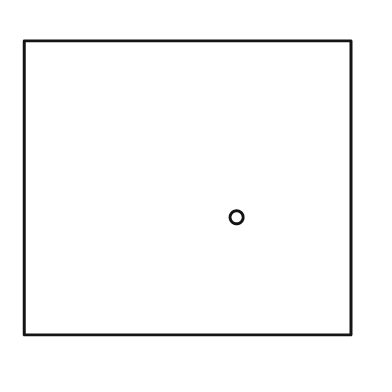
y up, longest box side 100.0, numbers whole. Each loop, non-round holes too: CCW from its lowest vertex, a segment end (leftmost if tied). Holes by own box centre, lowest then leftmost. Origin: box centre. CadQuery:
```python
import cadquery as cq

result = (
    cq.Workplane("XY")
    .moveTo(-50.0, -45.0)
    .lineTo(50.0, -45.0)
    .lineTo(50.0, 45.0)
    .lineTo(-50.0, 45.0)
    .close()
    .moveTo(15.0, -9.0)
    .circle(2.0)
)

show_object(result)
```